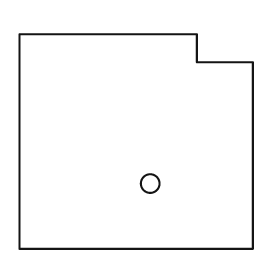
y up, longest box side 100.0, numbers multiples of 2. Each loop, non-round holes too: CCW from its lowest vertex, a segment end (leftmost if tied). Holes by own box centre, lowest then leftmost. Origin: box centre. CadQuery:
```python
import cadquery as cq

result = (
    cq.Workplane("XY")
    .moveTo(-50.0, -46.0)
    .lineTo(50.0, -46.0)
    .lineTo(50.0, 34.0)
    .lineTo(26.0, 34.0)
    .lineTo(26.0, 46.0)
    .lineTo(-50.0, 46.0)
    .close()
    .moveTo(6.0, -18.0)
    .circle(4.0)
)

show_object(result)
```